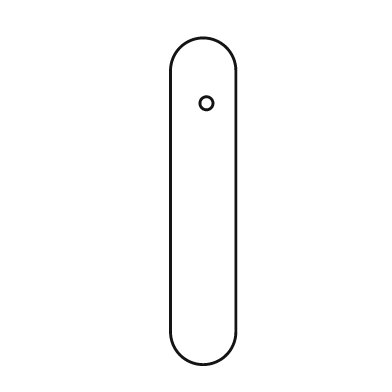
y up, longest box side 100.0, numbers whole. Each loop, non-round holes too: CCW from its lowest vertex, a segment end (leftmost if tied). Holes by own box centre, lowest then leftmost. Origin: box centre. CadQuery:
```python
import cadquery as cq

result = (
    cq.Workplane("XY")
    .moveTo(-10.0, -40.0)
    .threePointArc((0.0, -50.0), (10.0, -40.0))
    .lineTo(10.0, 40.0)
    .threePointArc((0.0, 50.0), (-10.0, 40.0))
    .close()
    .moveTo(1.0, 30.0)
    .circle(2.0)
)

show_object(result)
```